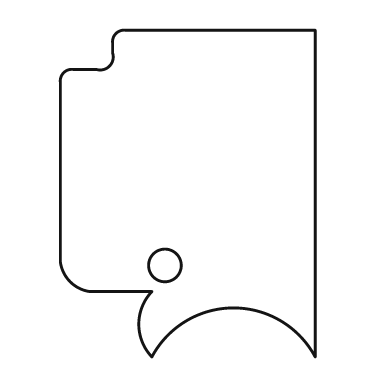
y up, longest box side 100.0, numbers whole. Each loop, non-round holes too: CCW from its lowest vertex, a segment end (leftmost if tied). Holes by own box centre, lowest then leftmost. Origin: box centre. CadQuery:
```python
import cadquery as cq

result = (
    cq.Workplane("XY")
    .moveTo(-11.0, -50.0)
    .threePointArc((14.0, -35.0), (39.0, -50.0))
    .lineTo(39.0, 50.0)
    .lineTo(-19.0, 50.0)
    .threePointArc((-22.0, 49.0), (-23.0, 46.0))
    .lineTo(-23.0, 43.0)
    .threePointArc((-24.0, 39.0), (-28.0, 38.0))
    .lineTo(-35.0, 38.0)
    .threePointArc((-38.0, 37.0), (-39.0, 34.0))
    .lineTo(-39.0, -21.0)
    .threePointArc((-36.0, -27.0), (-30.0, -30.0))
    .lineTo(-11.0, -30.0)
    .threePointArc((-15.0, -40.0), (-11.0, -50.0))
    .close()
    .moveTo(-7.0, -22.0)
    .circle(5.0)
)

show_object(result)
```